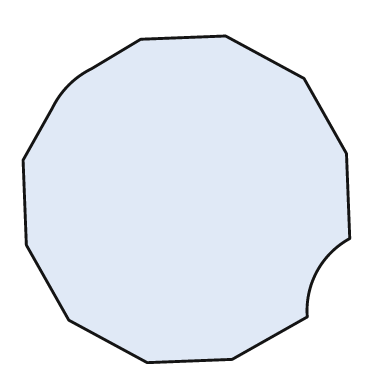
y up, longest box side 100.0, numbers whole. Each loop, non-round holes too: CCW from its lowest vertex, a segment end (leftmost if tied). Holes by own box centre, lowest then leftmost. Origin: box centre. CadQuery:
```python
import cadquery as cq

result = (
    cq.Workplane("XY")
    .moveTo(-12.0, -50.0)
    .lineTo(14.0, -49.0)
    .lineTo(37.0, -36.0)
    .threePointArc((40.0, -22.0), (50.0, -12.0))
    .lineTo(49.0, 14.0)
    .lineTo(36.0, 37.0)
    .lineTo(12.0, 50.0)
    .lineTo(-14.0, 49.0)
    .lineTo(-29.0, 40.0)
    .threePointArc((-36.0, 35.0), (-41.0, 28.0))
    .lineTo(-50.0, 12.0)
    .lineTo(-49.0, -14.0)
    .lineTo(-36.0, -37.0)
    .close()
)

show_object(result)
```